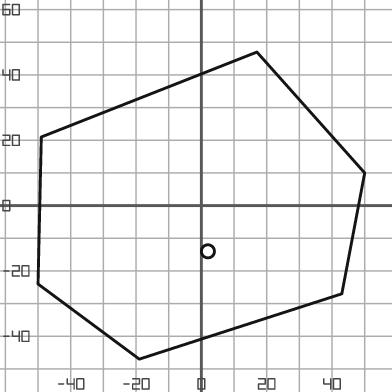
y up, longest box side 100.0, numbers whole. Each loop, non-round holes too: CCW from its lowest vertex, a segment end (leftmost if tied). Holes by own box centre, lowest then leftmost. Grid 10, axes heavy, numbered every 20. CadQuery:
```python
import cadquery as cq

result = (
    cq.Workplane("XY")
    .moveTo(-19.0, -47.0)
    .lineTo(43.0, -27.0)
    .lineTo(50.0, 10.0)
    .lineTo(17.0, 47.0)
    .lineTo(-49.0, 21.0)
    .lineTo(-50.0, -24.0)
    .close()
    .moveTo(2.0, -14.0)
    .circle(2.0)
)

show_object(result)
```